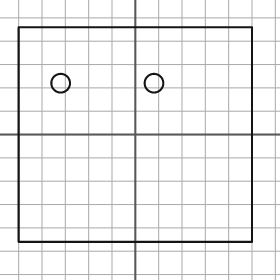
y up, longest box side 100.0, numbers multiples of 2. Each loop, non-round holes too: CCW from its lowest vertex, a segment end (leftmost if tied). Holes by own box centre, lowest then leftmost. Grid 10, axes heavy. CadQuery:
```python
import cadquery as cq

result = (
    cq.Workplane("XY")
    .moveTo(-50.0, -46.0)
    .lineTo(50.0, -46.0)
    .lineTo(50.0, 46.0)
    .lineTo(-50.0, 46.0)
    .close()
    .moveTo(-32.0, 22.0)
    .circle(4.0)
    .moveTo(8.0, 22.0)
    .circle(4.0)
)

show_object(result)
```